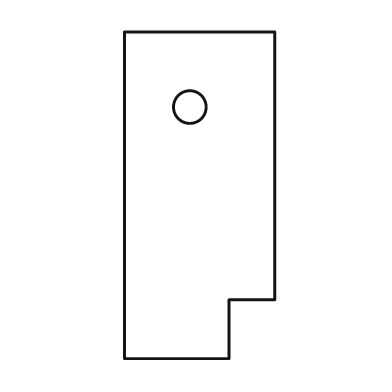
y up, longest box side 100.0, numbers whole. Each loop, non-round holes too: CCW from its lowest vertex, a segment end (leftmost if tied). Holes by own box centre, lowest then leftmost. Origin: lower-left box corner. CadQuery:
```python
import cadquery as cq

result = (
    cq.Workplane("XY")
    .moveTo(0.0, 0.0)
    .lineTo(32.0, 0.0)
    .lineTo(32.0, 18.0)
    .lineTo(46.0, 18.0)
    .lineTo(46.0, 100.0)
    .lineTo(0.0, 100.0)
    .close()
    .moveTo(20.0, 77.0)
    .circle(5.0)
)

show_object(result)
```